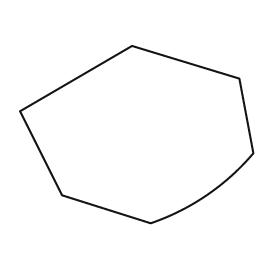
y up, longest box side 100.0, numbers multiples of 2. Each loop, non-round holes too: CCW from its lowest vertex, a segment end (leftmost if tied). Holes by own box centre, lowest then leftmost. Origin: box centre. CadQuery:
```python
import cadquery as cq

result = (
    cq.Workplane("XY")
    .moveTo(6.0, -38.0)
    .threePointArc((30.0, -26.0), (50.0, -8.0))
    .lineTo(44.0, 24.0)
    .lineTo(-2.0, 38.0)
    .lineTo(-50.0, 10.0)
    .lineTo(-32.0, -26.0)
    .close()
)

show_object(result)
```